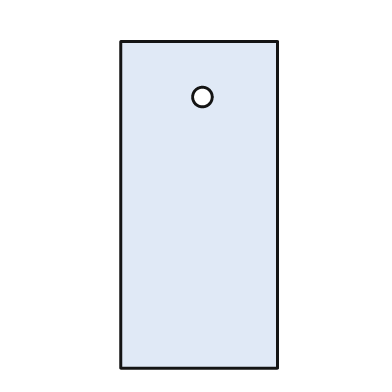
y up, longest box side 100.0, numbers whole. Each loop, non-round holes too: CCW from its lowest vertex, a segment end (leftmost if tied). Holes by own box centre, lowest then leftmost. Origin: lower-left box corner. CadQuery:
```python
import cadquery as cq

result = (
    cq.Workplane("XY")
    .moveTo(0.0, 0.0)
    .lineTo(48.0, 0.0)
    .lineTo(48.0, 100.0)
    .lineTo(0.0, 100.0)
    .close()
    .moveTo(25.0, 83.0)
    .circle(3.0)
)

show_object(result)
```